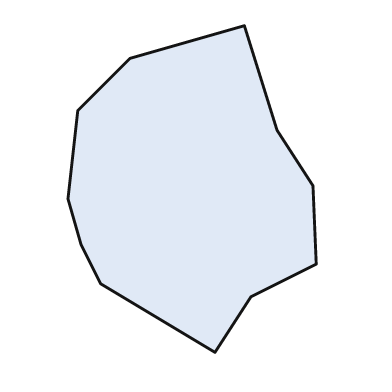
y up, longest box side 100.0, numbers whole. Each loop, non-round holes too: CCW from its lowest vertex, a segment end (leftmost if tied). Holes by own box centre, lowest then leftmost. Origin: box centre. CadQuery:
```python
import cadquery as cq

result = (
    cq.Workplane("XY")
    .moveTo(7.0, -50.0)
    .lineTo(18.0, -33.0)
    .lineTo(38.0, -23.0)
    .lineTo(37.0, 1.0)
    .lineTo(26.0, 18.0)
    .lineTo(16.0, 50.0)
    .lineTo(-19.0, 40.0)
    .lineTo(-35.0, 24.0)
    .lineTo(-38.0, -3.0)
    .lineTo(-34.0, -17.0)
    .lineTo(-28.0, -29.0)
    .close()
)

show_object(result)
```